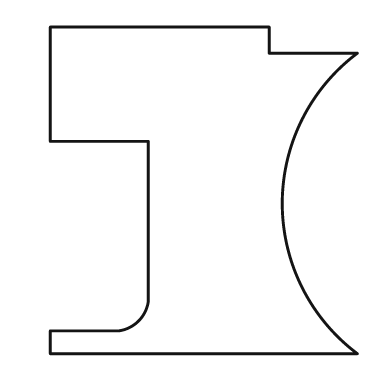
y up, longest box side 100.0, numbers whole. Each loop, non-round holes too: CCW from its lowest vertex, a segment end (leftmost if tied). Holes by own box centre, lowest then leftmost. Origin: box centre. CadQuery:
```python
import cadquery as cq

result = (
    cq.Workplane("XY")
    .moveTo(-47.0, -50.0)
    .lineTo(47.0, -50.0)
    .threePointArc((24.0, -4.0), (47.0, 42.0))
    .lineTo(20.0, 42.0)
    .lineTo(20.0, 50.0)
    .lineTo(-47.0, 50.0)
    .lineTo(-47.0, 15.0)
    .lineTo(-17.0, 15.0)
    .lineTo(-17.0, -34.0)
    .threePointArc((-20.0, -40.0), (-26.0, -43.0))
    .lineTo(-47.0, -43.0)
    .close()
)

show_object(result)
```